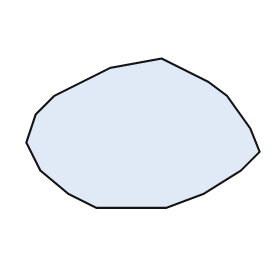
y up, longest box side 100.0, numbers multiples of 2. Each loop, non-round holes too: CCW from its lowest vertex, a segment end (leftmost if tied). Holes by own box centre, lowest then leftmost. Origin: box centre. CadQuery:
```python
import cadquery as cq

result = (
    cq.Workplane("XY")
    .moveTo(-20.0, -32.0)
    .lineTo(10.0, -32.0)
    .lineTo(26.0, -26.0)
    .lineTo(42.0, -16.0)
    .lineTo(50.0, -8.0)
    .lineTo(46.0, 2.0)
    .lineTo(36.0, 16.0)
    .lineTo(28.0, 22.0)
    .lineTo(8.0, 32.0)
    .lineTo(-14.0, 28.0)
    .lineTo(-38.0, 16.0)
    .lineTo(-46.0, 8.0)
    .lineTo(-50.0, -4.0)
    .lineTo(-44.0, -16.0)
    .lineTo(-32.0, -26.0)
    .close()
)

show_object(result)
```